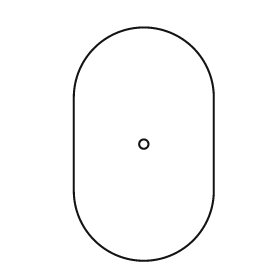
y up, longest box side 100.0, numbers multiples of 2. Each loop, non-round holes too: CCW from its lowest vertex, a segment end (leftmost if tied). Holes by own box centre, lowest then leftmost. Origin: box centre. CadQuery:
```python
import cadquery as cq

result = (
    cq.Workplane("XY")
    .moveTo(-30.0, -20.0)
    .threePointArc((0.0, -50.0), (30.0, -20.0))
    .lineTo(30.0, 20.0)
    .threePointArc((0.0, 50.0), (-30.0, 20.0))
    .close()
    .moveTo(0.0, 0.0)
    .circle(2.0)
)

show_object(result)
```